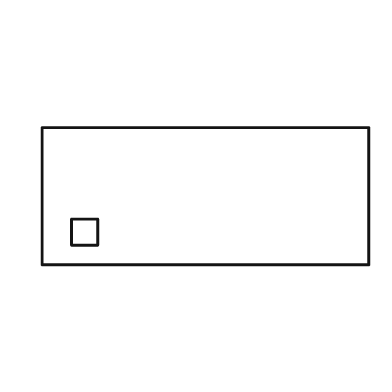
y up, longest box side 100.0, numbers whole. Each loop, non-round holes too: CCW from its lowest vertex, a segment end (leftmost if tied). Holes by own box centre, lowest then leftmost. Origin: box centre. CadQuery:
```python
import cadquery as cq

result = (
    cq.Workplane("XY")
    .moveTo(-50.0, -21.0)
    .lineTo(50.0, -21.0)
    .lineTo(50.0, 21.0)
    .lineTo(-50.0, 21.0)
    .close()
    .moveTo(-41.0, -15.0)
    .lineTo(-33.0, -15.0)
    .lineTo(-33.0, -7.0)
    .lineTo(-41.0, -7.0)
    .close()
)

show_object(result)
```